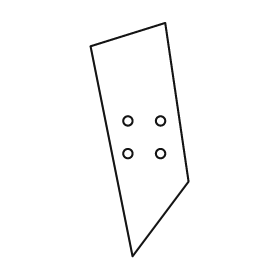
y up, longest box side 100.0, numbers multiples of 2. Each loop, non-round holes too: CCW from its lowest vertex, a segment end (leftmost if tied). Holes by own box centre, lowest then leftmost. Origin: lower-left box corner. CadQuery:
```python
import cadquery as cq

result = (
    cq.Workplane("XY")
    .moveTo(18.0, 0.0)
    .lineTo(42.0, 32.0)
    .lineTo(32.0, 100.0)
    .lineTo(0.0, 90.0)
    .close()
    .moveTo(16.0, 44.0)
    .circle(2.0)
    .moveTo(30.0, 44.0)
    .circle(2.0)
    .moveTo(16.0, 58.0)
    .circle(2.0)
    .moveTo(30.0, 58.0)
    .circle(2.0)
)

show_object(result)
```